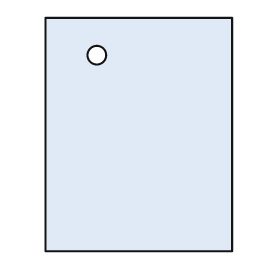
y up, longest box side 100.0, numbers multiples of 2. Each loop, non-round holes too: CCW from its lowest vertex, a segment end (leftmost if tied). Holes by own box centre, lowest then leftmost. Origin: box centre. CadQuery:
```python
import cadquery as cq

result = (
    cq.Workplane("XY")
    .moveTo(-40.0, -50.0)
    .lineTo(40.0, -50.0)
    .lineTo(40.0, 50.0)
    .lineTo(-40.0, 50.0)
    .close()
    .moveTo(-18.0, 34.0)
    .circle(4.0)
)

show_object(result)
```